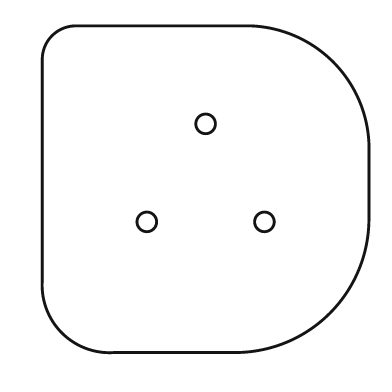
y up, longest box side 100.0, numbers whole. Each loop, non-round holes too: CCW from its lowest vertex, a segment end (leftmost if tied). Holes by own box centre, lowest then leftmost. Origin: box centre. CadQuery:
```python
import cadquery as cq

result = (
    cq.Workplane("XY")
    .moveTo(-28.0, -50.0)
    .lineTo(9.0, -50.0)
    .threePointArc((38.0, -38.0), (50.0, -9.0))
    .lineTo(50.0, 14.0)
    .threePointArc((39.0, 39.0), (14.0, 50.0))
    .lineTo(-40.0, 50.0)
    .threePointArc((-47.0, 47.0), (-50.0, 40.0))
    .lineTo(-50.0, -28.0)
    .threePointArc((-44.0, -44.0), (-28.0, -50.0))
    .close()
    .moveTo(-18.0, -10.0)
    .circle(3.0)
    .moveTo(18.0, -10.0)
    .circle(3.0)
    .moveTo(0.0, 20.0)
    .circle(3.0)
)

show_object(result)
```